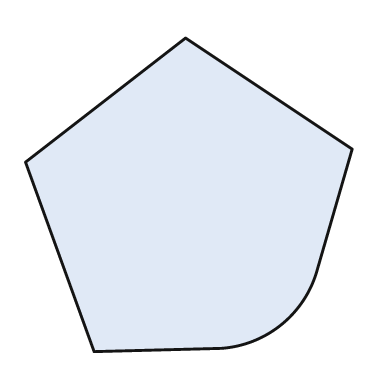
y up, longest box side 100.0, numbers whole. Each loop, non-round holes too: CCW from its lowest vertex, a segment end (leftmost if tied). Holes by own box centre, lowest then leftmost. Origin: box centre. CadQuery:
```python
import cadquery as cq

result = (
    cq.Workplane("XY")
    .moveTo(-29.0, -48.0)
    .lineTo(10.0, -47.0)
    .threePointArc((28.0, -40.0), (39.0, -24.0))
    .lineTo(50.0, 14.0)
    .lineTo(-1.0, 48.0)
    .lineTo(-50.0, 10.0)
    .close()
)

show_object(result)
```